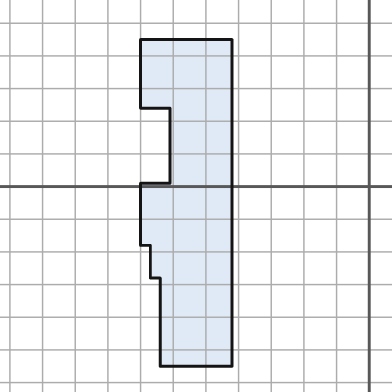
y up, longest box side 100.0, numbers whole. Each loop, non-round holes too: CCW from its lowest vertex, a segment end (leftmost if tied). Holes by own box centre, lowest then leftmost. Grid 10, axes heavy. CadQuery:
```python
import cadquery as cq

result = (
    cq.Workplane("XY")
    .moveTo(-64.0, -55.0)
    .lineTo(-42.0, -55.0)
    .lineTo(-42.0, 45.0)
    .lineTo(-70.0, 45.0)
    .lineTo(-70.0, 24.0)
    .lineTo(-61.0, 24.0)
    .lineTo(-61.0, 1.0)
    .lineTo(-70.0, 1.0)
    .lineTo(-70.0, -18.0)
    .lineTo(-67.0, -18.0)
    .lineTo(-67.0, -28.0)
    .lineTo(-64.0, -28.0)
    .close()
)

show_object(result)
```